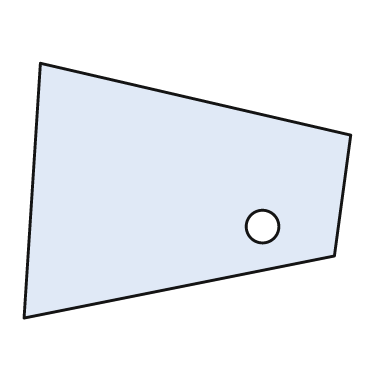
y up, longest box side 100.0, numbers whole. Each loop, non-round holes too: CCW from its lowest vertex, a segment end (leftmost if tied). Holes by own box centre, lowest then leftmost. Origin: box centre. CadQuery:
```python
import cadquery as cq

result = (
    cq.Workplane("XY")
    .moveTo(-50.0, -39.0)
    .lineTo(45.0, -20.0)
    .lineTo(50.0, 17.0)
    .lineTo(-45.0, 39.0)
    .close()
    .moveTo(23.0, -11.0)
    .circle(5.0)
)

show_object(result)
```